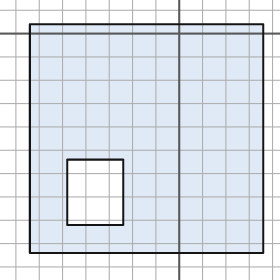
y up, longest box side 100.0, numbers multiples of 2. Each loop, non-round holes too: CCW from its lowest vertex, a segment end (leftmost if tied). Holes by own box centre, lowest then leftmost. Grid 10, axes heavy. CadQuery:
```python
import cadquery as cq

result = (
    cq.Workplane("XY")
    .moveTo(-64.0, -94.0)
    .lineTo(36.0, -94.0)
    .lineTo(36.0, 4.0)
    .lineTo(-64.0, 4.0)
    .close()
    .moveTo(-48.0, -82.0)
    .lineTo(-24.0, -82.0)
    .lineTo(-24.0, -54.0)
    .lineTo(-48.0, -54.0)
    .close()
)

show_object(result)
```